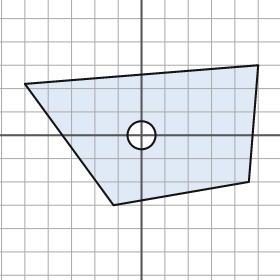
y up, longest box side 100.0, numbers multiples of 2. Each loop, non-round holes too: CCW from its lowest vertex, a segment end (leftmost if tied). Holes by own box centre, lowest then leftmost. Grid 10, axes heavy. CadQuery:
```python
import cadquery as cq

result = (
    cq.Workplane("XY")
    .moveTo(-12.0, -30.0)
    .lineTo(46.0, -20.0)
    .lineTo(50.0, 30.0)
    .lineTo(-50.0, 22.0)
    .close()
    .moveTo(0.0, 0.0)
    .circle(6.0)
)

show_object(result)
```